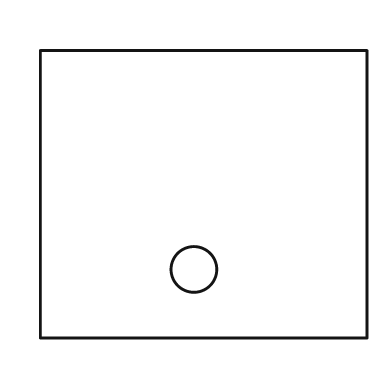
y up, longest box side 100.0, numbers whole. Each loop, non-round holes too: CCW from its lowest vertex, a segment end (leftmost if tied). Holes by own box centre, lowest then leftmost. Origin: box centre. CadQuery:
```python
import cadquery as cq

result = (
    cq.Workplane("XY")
    .moveTo(-50.0, -44.0)
    .lineTo(50.0, -44.0)
    .lineTo(50.0, 44.0)
    .lineTo(-50.0, 44.0)
    .close()
    .moveTo(-3.0, -23.0)
    .circle(7.0)
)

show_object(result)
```